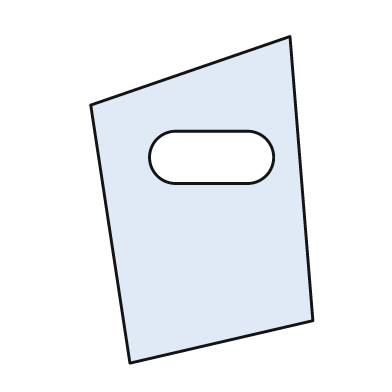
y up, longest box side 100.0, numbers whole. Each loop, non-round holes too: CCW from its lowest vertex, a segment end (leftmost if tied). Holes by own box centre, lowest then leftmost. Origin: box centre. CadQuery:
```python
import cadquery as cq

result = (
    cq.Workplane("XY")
    .moveTo(-22.0, -50.0)
    .lineTo(34.0, -37.0)
    .lineTo(27.0, 50.0)
    .lineTo(-34.0, 29.0)
    .close()
    .moveTo(-8.0, 5.0)
    .lineTo(14.0, 5.0)
    .threePointArc((22.0, 13.0), (14.0, 21.0))
    .lineTo(-8.0, 21.0)
    .threePointArc((-16.0, 13.0), (-8.0, 5.0))
    .close()
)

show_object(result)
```